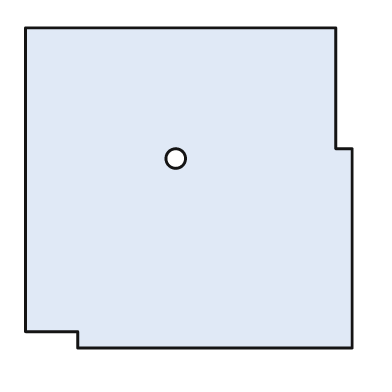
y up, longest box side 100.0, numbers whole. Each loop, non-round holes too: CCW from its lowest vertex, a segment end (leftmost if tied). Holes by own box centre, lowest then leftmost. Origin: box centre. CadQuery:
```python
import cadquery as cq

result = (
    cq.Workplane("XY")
    .moveTo(-34.0, -49.0)
    .lineTo(50.0, -49.0)
    .lineTo(50.0, 12.0)
    .lineTo(45.0, 12.0)
    .lineTo(45.0, 49.0)
    .lineTo(-50.0, 49.0)
    .lineTo(-50.0, -44.0)
    .lineTo(-34.0, -44.0)
    .close()
    .moveTo(-4.0, 9.0)
    .circle(3.0)
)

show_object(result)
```